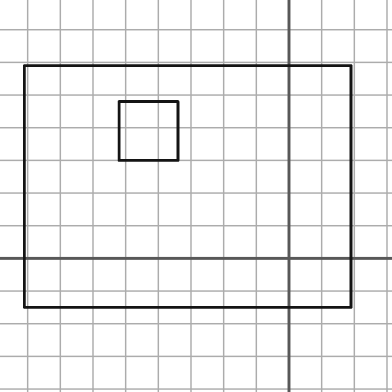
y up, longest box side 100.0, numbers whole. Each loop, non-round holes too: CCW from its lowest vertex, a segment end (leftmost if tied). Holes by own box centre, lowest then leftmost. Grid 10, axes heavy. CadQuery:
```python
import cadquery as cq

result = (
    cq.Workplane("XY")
    .moveTo(-81.0, -15.0)
    .lineTo(19.0, -15.0)
    .lineTo(19.0, 59.0)
    .lineTo(-81.0, 59.0)
    .close()
    .moveTo(-52.0, 30.0)
    .lineTo(-34.0, 30.0)
    .lineTo(-34.0, 48.0)
    .lineTo(-52.0, 48.0)
    .close()
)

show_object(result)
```